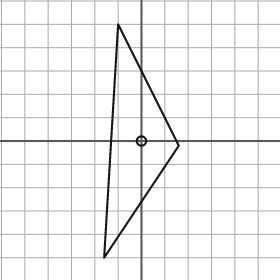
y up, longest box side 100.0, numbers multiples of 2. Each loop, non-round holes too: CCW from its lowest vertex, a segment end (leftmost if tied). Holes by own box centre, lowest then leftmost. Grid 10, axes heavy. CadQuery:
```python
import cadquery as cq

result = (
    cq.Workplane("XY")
    .moveTo(-16.0, -50.0)
    .lineTo(16.0, -2.0)
    .lineTo(-10.0, 50.0)
    .close()
    .moveTo(0.0, 0.0)
    .circle(2.0)
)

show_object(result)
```